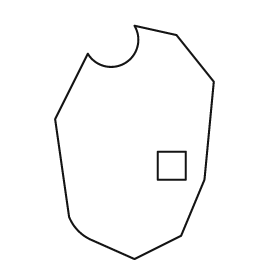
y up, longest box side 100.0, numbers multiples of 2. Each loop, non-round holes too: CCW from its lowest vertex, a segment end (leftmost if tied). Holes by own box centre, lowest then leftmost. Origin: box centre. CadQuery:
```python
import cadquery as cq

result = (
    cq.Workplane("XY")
    .moveTo(0.0, -50.0)
    .lineTo(20.0, -40.0)
    .lineTo(30.0, -16.0)
    .lineTo(34.0, 26.0)
    .lineTo(18.0, 46.0)
    .lineTo(0.0, 50.0)
    .threePointArc((-4.0, 34.0), (-20.0, 38.0))
    .lineTo(-34.0, 10.0)
    .lineTo(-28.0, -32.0)
    .threePointArc((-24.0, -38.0), (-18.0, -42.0))
    .close()
    .moveTo(10.0, -16.0)
    .lineTo(22.0, -16.0)
    .lineTo(22.0, -4.0)
    .lineTo(10.0, -4.0)
    .close()
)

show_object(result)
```